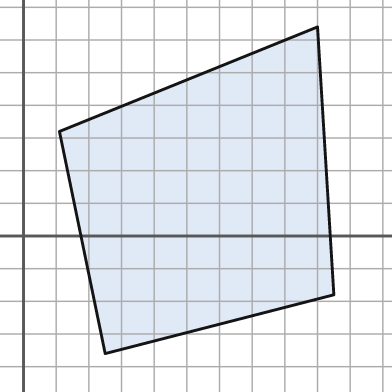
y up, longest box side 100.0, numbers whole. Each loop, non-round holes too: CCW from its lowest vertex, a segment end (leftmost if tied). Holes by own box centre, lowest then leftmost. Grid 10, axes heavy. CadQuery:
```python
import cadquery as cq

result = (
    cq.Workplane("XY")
    .moveTo(25.0, -36.0)
    .lineTo(95.0, -18.0)
    .lineTo(90.0, 64.0)
    .lineTo(11.0, 32.0)
    .close()
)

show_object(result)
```